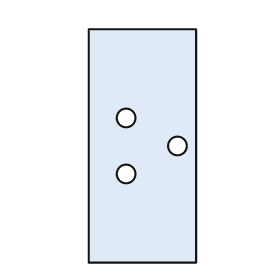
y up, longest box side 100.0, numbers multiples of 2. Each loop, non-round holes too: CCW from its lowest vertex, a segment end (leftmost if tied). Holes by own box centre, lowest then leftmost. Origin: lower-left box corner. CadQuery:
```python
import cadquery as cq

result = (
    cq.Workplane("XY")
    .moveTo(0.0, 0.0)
    .lineTo(46.0, 0.0)
    .lineTo(46.0, 100.0)
    .lineTo(0.0, 100.0)
    .close()
    .moveTo(16.0, 38.0)
    .circle(4.0)
    .moveTo(38.0, 50.0)
    .circle(4.0)
    .moveTo(16.0, 62.0)
    .circle(4.0)
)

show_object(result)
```